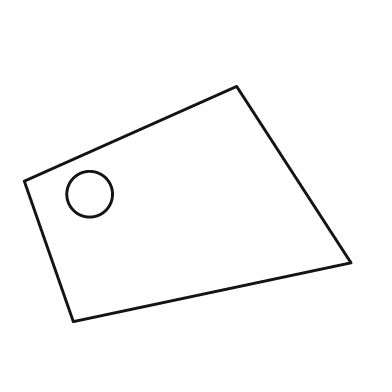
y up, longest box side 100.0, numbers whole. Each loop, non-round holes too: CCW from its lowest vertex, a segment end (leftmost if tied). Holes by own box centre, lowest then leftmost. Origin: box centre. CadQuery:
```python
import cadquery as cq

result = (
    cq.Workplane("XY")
    .moveTo(-35.0, -36.0)
    .lineTo(50.0, -18.0)
    .lineTo(15.0, 36.0)
    .lineTo(-50.0, 7.0)
    .close()
    .moveTo(-30.0, 3.0)
    .circle(7.0)
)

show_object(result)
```